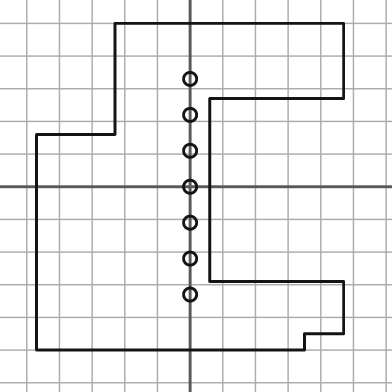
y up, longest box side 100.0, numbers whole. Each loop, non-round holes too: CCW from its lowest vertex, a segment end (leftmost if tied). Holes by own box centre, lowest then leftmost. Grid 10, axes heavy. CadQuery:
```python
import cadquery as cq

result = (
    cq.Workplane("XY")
    .moveTo(-47.0, -50.0)
    .lineTo(35.0, -50.0)
    .lineTo(35.0, -45.0)
    .lineTo(47.0, -45.0)
    .lineTo(47.0, -29.0)
    .lineTo(6.0, -29.0)
    .lineTo(6.0, 27.0)
    .lineTo(47.0, 27.0)
    .lineTo(47.0, 50.0)
    .lineTo(-23.0, 50.0)
    .lineTo(-23.0, 16.0)
    .lineTo(-47.0, 16.0)
    .close()
    .moveTo(0.0, -33.0)
    .circle(2.0)
    .moveTo(0.0, -22.0)
    .circle(2.0)
    .moveTo(0.0, -11.0)
    .circle(2.0)
    .moveTo(0.0, 0.0)
    .circle(2.0)
    .moveTo(0.0, 11.0)
    .circle(2.0)
    .moveTo(0.0, 22.0)
    .circle(2.0)
    .moveTo(0.0, 33.0)
    .circle(2.0)
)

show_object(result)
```